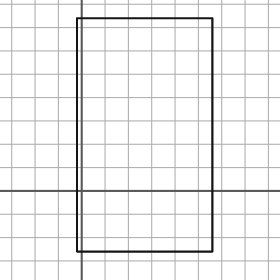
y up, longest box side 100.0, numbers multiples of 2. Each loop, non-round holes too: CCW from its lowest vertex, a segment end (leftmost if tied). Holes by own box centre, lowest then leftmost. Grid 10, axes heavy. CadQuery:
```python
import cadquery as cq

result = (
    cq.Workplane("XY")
    .moveTo(-2.0, -26.0)
    .lineTo(56.0, -26.0)
    .lineTo(56.0, 74.0)
    .lineTo(-2.0, 74.0)
    .close()
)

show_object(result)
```